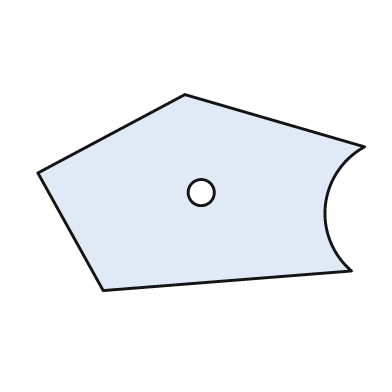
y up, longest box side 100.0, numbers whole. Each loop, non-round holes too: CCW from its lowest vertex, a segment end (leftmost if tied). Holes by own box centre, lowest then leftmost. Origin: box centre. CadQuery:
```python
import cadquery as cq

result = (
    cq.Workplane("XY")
    .moveTo(-30.0, -30.0)
    .lineTo(46.0, -24.0)
    .threePointArc((38.0, -4.0), (50.0, 14.0))
    .lineTo(-5.0, 30.0)
    .lineTo(-50.0, 6.0)
    .close()
    .moveTo(0.0, 0.0)
    .circle(4.0)
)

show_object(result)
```